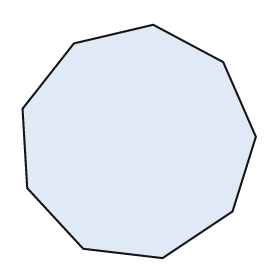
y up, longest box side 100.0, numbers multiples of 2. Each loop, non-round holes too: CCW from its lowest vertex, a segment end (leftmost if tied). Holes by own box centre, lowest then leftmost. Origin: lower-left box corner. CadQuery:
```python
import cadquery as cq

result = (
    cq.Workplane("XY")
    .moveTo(60.0, 0.0)
    .lineTo(90.0, 20.0)
    .lineTo(100.0, 52.0)
    .lineTo(86.0, 84.0)
    .lineTo(56.0, 100.0)
    .lineTo(22.0, 92.0)
    .lineTo(0.0, 64.0)
    .lineTo(2.0, 30.0)
    .lineTo(26.0, 4.0)
    .close()
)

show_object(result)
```